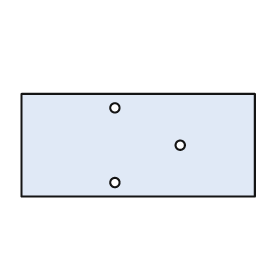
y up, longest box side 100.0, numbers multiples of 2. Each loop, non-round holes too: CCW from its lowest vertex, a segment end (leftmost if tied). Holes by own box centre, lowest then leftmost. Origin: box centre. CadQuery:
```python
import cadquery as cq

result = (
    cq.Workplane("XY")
    .moveTo(-50.0, -22.0)
    .lineTo(50.0, -22.0)
    .lineTo(50.0, 22.0)
    .lineTo(-50.0, 22.0)
    .close()
    .moveTo(-10.0, -16.0)
    .circle(2.0)
    .moveTo(18.0, 0.0)
    .circle(2.0)
    .moveTo(-10.0, 16.0)
    .circle(2.0)
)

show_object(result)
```